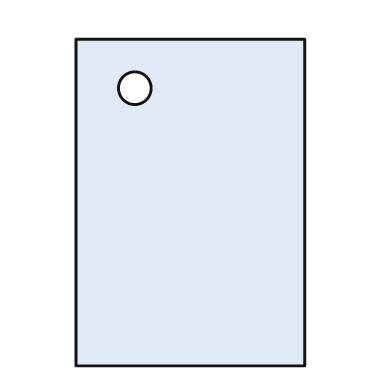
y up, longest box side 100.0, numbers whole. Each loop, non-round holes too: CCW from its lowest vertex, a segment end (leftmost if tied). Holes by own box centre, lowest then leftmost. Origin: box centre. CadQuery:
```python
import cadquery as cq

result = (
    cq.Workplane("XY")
    .moveTo(-35.0, -50.0)
    .lineTo(35.0, -50.0)
    .lineTo(35.0, 50.0)
    .lineTo(-35.0, 50.0)
    .close()
    .moveTo(-17.0, 35.0)
    .circle(5.0)
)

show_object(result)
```